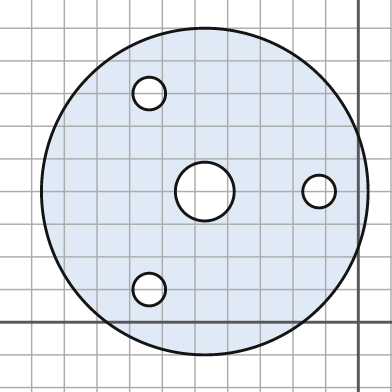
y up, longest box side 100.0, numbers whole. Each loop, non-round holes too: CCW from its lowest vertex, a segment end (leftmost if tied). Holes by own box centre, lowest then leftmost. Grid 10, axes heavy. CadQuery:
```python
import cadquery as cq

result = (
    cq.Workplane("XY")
    .moveTo(-47.0, 40.0)
    .circle(50.0)
    .moveTo(-64.0, 10.0)
    .circle(5.0)
    .moveTo(-47.0, 40.0)
    .circle(9.0)
    .moveTo(-12.0, 40.0)
    .circle(5.0)
    .moveTo(-64.0, 70.0)
    .circle(5.0)
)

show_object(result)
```